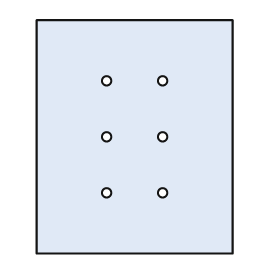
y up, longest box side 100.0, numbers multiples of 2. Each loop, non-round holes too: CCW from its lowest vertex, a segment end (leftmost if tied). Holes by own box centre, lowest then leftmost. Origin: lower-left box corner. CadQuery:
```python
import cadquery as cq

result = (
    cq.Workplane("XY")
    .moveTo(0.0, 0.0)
    .lineTo(84.0, 0.0)
    .lineTo(84.0, 100.0)
    .lineTo(0.0, 100.0)
    .close()
    .moveTo(30.0, 26.0)
    .circle(2.0)
    .moveTo(54.0, 26.0)
    .circle(2.0)
    .moveTo(30.0, 50.0)
    .circle(2.0)
    .moveTo(54.0, 50.0)
    .circle(2.0)
    .moveTo(30.0, 74.0)
    .circle(2.0)
    .moveTo(54.0, 74.0)
    .circle(2.0)
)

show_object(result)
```